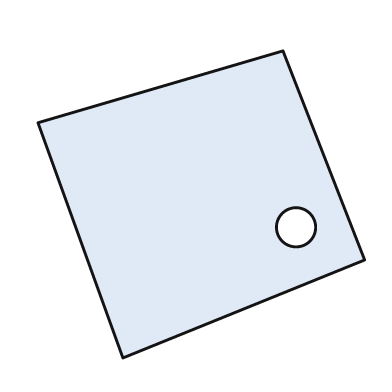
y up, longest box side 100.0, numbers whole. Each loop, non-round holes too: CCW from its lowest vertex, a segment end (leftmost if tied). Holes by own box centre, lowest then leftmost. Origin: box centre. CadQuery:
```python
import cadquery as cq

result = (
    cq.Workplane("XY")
    .moveTo(-24.0, -47.0)
    .lineTo(50.0, -17.0)
    .lineTo(25.0, 47.0)
    .lineTo(-50.0, 25.0)
    .close()
    .moveTo(29.0, -7.0)
    .circle(6.0)
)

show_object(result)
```